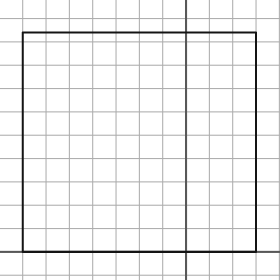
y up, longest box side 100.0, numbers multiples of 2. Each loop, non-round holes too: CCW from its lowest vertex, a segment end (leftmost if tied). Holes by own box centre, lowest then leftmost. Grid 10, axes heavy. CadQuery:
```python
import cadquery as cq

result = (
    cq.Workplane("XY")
    .moveTo(-70.0, 0.0)
    .lineTo(30.0, 0.0)
    .lineTo(30.0, 94.0)
    .lineTo(-70.0, 94.0)
    .close()
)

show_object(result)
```